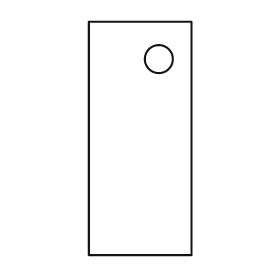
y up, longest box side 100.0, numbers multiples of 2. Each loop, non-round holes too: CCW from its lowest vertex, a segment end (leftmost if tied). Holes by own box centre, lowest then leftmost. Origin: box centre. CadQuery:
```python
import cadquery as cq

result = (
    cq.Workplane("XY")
    .moveTo(-22.0, -50.0)
    .lineTo(22.0, -50.0)
    .lineTo(22.0, 50.0)
    .lineTo(-22.0, 50.0)
    .close()
    .moveTo(8.0, 34.0)
    .circle(6.0)
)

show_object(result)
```